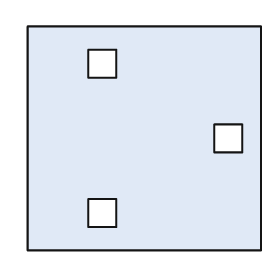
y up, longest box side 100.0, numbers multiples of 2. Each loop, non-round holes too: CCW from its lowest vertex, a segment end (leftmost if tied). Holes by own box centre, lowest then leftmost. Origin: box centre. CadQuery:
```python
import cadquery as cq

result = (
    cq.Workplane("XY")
    .moveTo(-50.0, -48.0)
    .lineTo(50.0, -48.0)
    .lineTo(50.0, 48.0)
    .lineTo(-50.0, 48.0)
    .close()
    .moveTo(-24.0, -38.0)
    .lineTo(-12.0, -38.0)
    .lineTo(-12.0, -26.0)
    .lineTo(-24.0, -26.0)
    .close()
    .moveTo(30.0, -6.0)
    .lineTo(42.0, -6.0)
    .lineTo(42.0, 6.0)
    .lineTo(30.0, 6.0)
    .close()
    .moveTo(-24.0, 26.0)
    .lineTo(-12.0, 26.0)
    .lineTo(-12.0, 38.0)
    .lineTo(-24.0, 38.0)
    .close()
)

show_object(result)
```